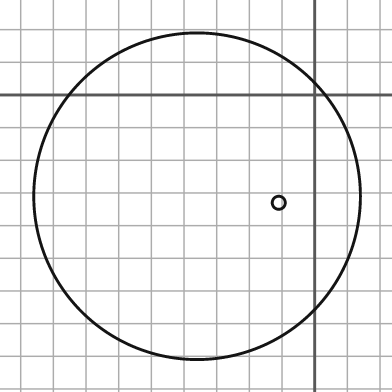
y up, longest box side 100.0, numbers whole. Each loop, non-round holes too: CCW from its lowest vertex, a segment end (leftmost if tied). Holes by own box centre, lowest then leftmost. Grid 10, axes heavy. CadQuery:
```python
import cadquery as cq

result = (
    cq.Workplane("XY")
    .moveTo(-36.0, -31.0)
    .circle(50.0)
    .moveTo(-11.0, -33.0)
    .circle(2.0)
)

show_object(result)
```